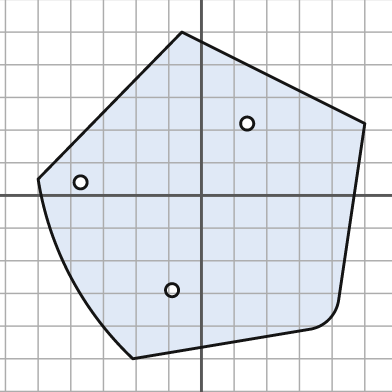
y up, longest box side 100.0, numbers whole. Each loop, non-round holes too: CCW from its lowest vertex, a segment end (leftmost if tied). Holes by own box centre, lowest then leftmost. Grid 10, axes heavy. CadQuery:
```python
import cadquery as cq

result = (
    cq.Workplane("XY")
    .moveTo(-21.0, -50.0)
    .lineTo(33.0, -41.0)
    .threePointArc((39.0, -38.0), (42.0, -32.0))
    .lineTo(50.0, 22.0)
    .lineTo(-6.0, 50.0)
    .lineTo(-50.0, 5.0)
    .threePointArc((-40.0, -25.0), (-21.0, -50.0))
    .close()
    .moveTo(-9.0, -29.0)
    .circle(2.0)
    .moveTo(-37.0, 4.0)
    .circle(2.0)
    .moveTo(14.0, 22.0)
    .circle(2.0)
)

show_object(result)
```